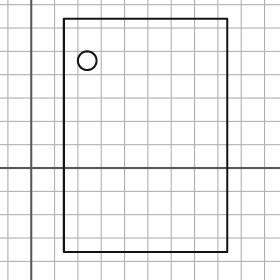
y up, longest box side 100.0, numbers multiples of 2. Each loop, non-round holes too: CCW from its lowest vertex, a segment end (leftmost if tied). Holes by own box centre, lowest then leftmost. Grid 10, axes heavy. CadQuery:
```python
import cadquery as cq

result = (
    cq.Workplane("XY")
    .moveTo(14.0, -36.0)
    .lineTo(84.0, -36.0)
    .lineTo(84.0, 64.0)
    .lineTo(14.0, 64.0)
    .close()
    .moveTo(24.0, 46.0)
    .circle(4.0)
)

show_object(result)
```